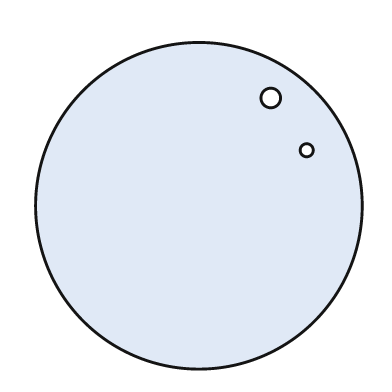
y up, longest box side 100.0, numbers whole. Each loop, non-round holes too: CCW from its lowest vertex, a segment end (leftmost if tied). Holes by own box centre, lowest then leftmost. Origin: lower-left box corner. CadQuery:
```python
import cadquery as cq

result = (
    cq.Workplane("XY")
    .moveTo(50.0, 50.0)
    .circle(50.0)
    .moveTo(83.0, 67.0)
    .circle(2.0)
    .moveTo(72.0, 83.0)
    .circle(3.0)
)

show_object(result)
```